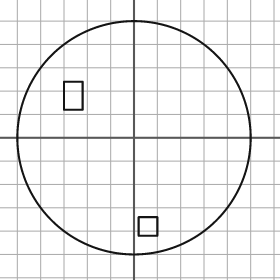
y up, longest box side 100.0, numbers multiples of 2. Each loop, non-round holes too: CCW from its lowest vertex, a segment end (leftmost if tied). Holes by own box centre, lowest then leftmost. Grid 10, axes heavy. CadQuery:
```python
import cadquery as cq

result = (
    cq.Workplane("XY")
    .moveTo(0.0, 0.0)
    .circle(50.0)
    .moveTo(2.0, -42.0)
    .lineTo(10.0, -42.0)
    .lineTo(10.0, -34.0)
    .lineTo(2.0, -34.0)
    .close()
    .moveTo(-30.0, 12.0)
    .lineTo(-22.0, 12.0)
    .lineTo(-22.0, 24.0)
    .lineTo(-30.0, 24.0)
    .close()
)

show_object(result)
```